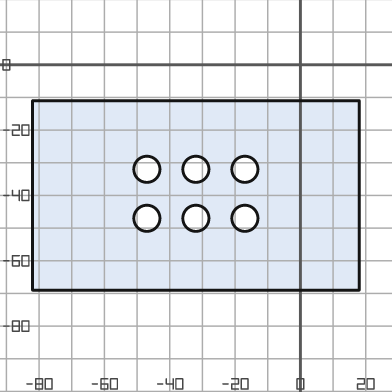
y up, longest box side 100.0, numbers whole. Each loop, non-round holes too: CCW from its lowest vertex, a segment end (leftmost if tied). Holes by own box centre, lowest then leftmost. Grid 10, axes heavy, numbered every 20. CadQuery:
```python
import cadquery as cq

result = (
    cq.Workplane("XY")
    .moveTo(-82.0, -69.0)
    .lineTo(18.0, -69.0)
    .lineTo(18.0, -11.0)
    .lineTo(-82.0, -11.0)
    .close()
    .moveTo(-47.0, -47.0)
    .circle(4.0)
    .moveTo(-32.0, -47.0)
    .circle(4.0)
    .moveTo(-17.0, -47.0)
    .circle(4.0)
    .moveTo(-47.0, -32.0)
    .circle(4.0)
    .moveTo(-32.0, -32.0)
    .circle(4.0)
    .moveTo(-17.0, -32.0)
    .circle(4.0)
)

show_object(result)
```